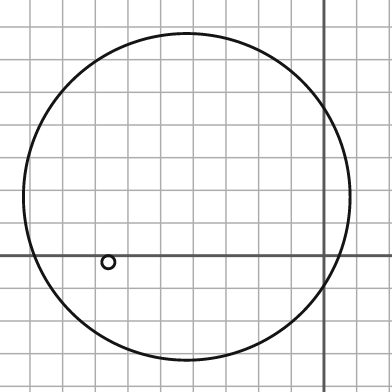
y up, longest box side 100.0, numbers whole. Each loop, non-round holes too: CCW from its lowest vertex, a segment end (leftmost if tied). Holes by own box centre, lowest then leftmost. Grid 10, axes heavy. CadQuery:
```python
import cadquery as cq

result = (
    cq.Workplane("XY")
    .moveTo(-42.0, 18.0)
    .circle(50.0)
    .moveTo(-66.0, -2.0)
    .circle(2.0)
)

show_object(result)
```